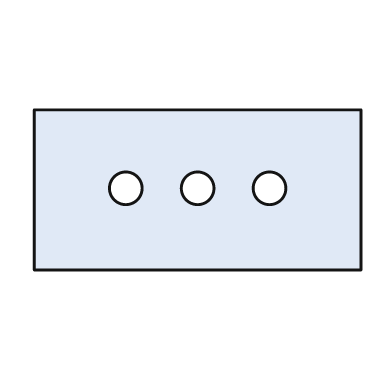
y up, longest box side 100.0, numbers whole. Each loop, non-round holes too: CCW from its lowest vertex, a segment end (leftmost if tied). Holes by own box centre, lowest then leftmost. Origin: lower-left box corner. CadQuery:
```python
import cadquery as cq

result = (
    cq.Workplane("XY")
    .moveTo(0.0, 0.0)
    .lineTo(100.0, 0.0)
    .lineTo(100.0, 49.0)
    .lineTo(0.0, 49.0)
    .close()
    .moveTo(28.0, 25.0)
    .circle(5.0)
    .moveTo(50.0, 25.0)
    .circle(5.0)
    .moveTo(72.0, 25.0)
    .circle(5.0)
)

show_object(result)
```